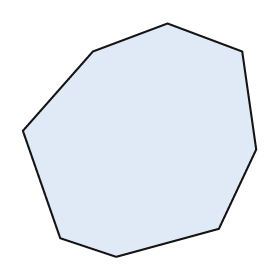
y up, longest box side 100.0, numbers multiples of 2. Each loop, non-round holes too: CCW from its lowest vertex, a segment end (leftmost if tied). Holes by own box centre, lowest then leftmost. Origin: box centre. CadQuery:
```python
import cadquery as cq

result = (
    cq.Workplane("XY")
    .moveTo(-10.0, -50.0)
    .lineTo(34.0, -38.0)
    .lineTo(50.0, -4.0)
    .lineTo(44.0, 38.0)
    .lineTo(12.0, 50.0)
    .lineTo(-20.0, 38.0)
    .lineTo(-50.0, 4.0)
    .lineTo(-34.0, -42.0)
    .close()
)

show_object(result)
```